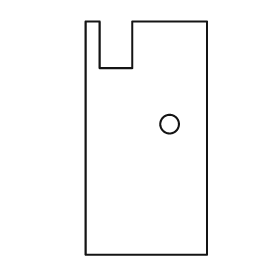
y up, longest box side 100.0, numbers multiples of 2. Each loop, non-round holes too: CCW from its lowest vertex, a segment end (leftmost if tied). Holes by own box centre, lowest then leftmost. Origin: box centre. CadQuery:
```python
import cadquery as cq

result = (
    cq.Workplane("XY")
    .moveTo(-26.0, -50.0)
    .lineTo(26.0, -50.0)
    .lineTo(26.0, 50.0)
    .lineTo(-6.0, 50.0)
    .lineTo(-6.0, 30.0)
    .lineTo(-20.0, 30.0)
    .lineTo(-20.0, 50.0)
    .lineTo(-26.0, 50.0)
    .close()
    .moveTo(10.0, 6.0)
    .circle(4.0)
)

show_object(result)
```